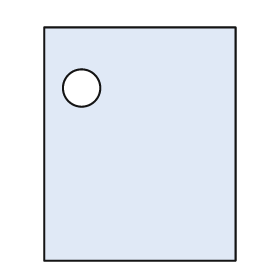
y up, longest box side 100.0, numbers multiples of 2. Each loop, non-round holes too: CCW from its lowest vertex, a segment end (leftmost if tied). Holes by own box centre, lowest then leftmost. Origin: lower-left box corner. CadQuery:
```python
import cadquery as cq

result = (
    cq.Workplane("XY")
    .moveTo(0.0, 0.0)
    .lineTo(82.0, 0.0)
    .lineTo(82.0, 100.0)
    .lineTo(0.0, 100.0)
    .close()
    .moveTo(16.0, 74.0)
    .circle(8.0)
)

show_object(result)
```